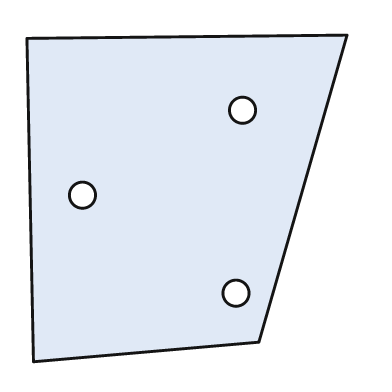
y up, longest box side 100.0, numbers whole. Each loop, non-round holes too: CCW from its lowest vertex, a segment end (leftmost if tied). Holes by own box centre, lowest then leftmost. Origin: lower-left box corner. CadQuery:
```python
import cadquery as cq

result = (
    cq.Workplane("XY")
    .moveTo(2.0, 0.0)
    .lineTo(71.0, 6.0)
    .lineTo(98.0, 100.0)
    .lineTo(0.0, 99.0)
    .close()
    .moveTo(64.0, 21.0)
    .circle(4.0)
    .moveTo(17.0, 51.0)
    .circle(4.0)
    .moveTo(66.0, 77.0)
    .circle(4.0)
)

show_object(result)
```